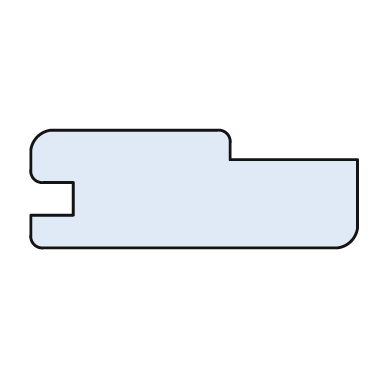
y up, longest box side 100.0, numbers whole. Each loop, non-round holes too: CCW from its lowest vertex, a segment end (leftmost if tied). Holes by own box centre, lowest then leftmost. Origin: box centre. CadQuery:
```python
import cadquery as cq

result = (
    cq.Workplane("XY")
    .moveTo(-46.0, -18.0)
    .lineTo(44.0, -18.0)
    .threePointArc((48.0, -16.0), (50.0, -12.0))
    .lineTo(50.0, 9.0)
    .lineTo(11.0, 9.0)
    .lineTo(11.0, 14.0)
    .threePointArc((10.0, 17.0), (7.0, 18.0))
    .lineTo(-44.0, 18.0)
    .threePointArc((-48.0, 16.0), (-50.0, 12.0))
    .lineTo(-50.0, 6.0)
    .threePointArc((-49.0, 3.0), (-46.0, 2.0))
    .lineTo(-37.0, 2.0)
    .lineTo(-37.0, -8.0)
    .lineTo(-50.0, -8.0)
    .lineTo(-50.0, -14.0)
    .threePointArc((-49.0, -17.0), (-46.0, -18.0))
    .close()
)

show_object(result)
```